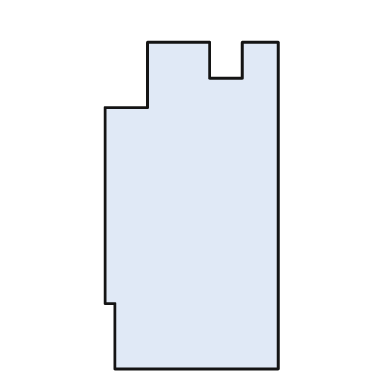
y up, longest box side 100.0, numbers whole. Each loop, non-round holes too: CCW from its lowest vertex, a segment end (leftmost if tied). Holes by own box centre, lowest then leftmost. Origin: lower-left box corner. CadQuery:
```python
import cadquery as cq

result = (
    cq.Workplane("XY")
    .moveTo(3.0, 0.0)
    .lineTo(53.0, 0.0)
    .lineTo(53.0, 100.0)
    .lineTo(42.0, 100.0)
    .lineTo(42.0, 89.0)
    .lineTo(32.0, 89.0)
    .lineTo(32.0, 100.0)
    .lineTo(13.0, 100.0)
    .lineTo(13.0, 80.0)
    .lineTo(0.0, 80.0)
    .lineTo(0.0, 20.0)
    .lineTo(3.0, 20.0)
    .close()
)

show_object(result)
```